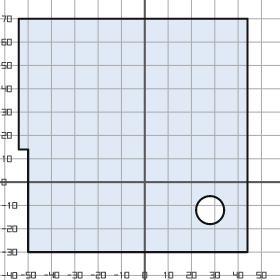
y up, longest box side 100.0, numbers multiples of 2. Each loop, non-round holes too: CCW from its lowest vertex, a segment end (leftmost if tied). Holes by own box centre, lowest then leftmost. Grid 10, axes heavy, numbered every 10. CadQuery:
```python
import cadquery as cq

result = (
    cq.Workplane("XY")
    .moveTo(-50.0, -30.0)
    .lineTo(44.0, -30.0)
    .lineTo(44.0, 70.0)
    .lineTo(-54.0, 70.0)
    .lineTo(-54.0, 14.0)
    .lineTo(-50.0, 14.0)
    .close()
    .moveTo(28.0, -12.0)
    .circle(6.0)
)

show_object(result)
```